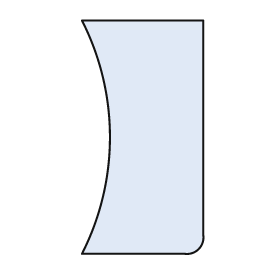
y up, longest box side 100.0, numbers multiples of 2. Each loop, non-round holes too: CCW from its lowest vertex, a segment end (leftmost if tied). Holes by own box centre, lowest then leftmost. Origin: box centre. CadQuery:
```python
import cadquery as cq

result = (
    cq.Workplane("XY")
    .moveTo(-26.0, -50.0)
    .lineTo(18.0, -50.0)
    .threePointArc((24.0, -48.0), (26.0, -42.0))
    .lineTo(26.0, 50.0)
    .lineTo(-26.0, 50.0)
    .threePointArc((-14.0, 0.0), (-26.0, -50.0))
    .close()
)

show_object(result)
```